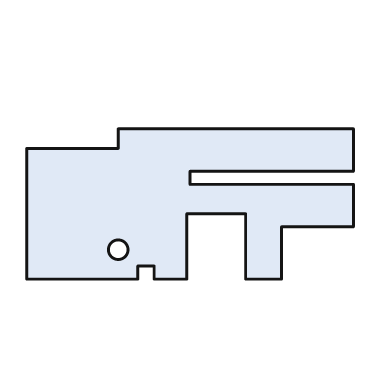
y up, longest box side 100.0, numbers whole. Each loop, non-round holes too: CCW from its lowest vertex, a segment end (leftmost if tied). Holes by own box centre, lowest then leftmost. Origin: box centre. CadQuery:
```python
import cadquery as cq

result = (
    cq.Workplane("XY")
    .moveTo(-50.0, -23.0)
    .lineTo(-16.0, -23.0)
    .lineTo(-16.0, -19.0)
    .lineTo(-11.0, -19.0)
    .lineTo(-11.0, -23.0)
    .lineTo(-1.0, -23.0)
    .lineTo(-1.0, -3.0)
    .lineTo(17.0, -3.0)
    .lineTo(17.0, -23.0)
    .lineTo(28.0, -23.0)
    .lineTo(28.0, -7.0)
    .lineTo(50.0, -7.0)
    .lineTo(50.0, 6.0)
    .lineTo(0.0, 6.0)
    .lineTo(0.0, 10.0)
    .lineTo(50.0, 10.0)
    .lineTo(50.0, 23.0)
    .lineTo(-22.0, 23.0)
    .lineTo(-22.0, 17.0)
    .lineTo(-50.0, 17.0)
    .close()
    .moveTo(-22.0, -14.0)
    .circle(3.0)
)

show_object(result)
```